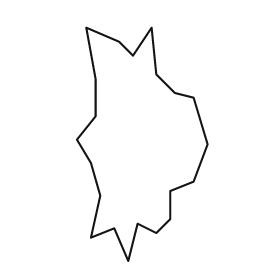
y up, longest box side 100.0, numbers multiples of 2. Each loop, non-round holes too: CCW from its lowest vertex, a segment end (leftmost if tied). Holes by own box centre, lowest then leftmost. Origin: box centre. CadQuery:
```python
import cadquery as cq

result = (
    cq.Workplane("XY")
    .moveTo(-6.0, -50.0)
    .lineTo(-2.0, -34.0)
    .lineTo(6.0, -38.0)
    .lineTo(12.0, -32.0)
    .lineTo(12.0, -20.0)
    .lineTo(22.0, -16.0)
    .lineTo(28.0, 0.0)
    .lineTo(22.0, 20.0)
    .lineTo(14.0, 22.0)
    .lineTo(6.0, 30.0)
    .lineTo(4.0, 50.0)
    .lineTo(-4.0, 38.0)
    .lineTo(-10.0, 44.0)
    .lineTo(-24.0, 50.0)
    .lineTo(-20.0, 28.0)
    .lineTo(-20.0, 12.0)
    .lineTo(-28.0, 2.0)
    .lineTo(-22.0, -8.0)
    .lineTo(-18.0, -22.0)
    .lineTo(-22.0, -40.0)
    .lineTo(-12.0, -36.0)
    .close()
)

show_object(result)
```